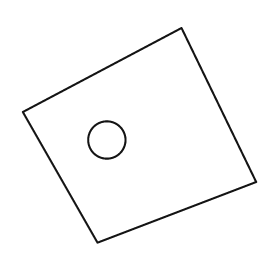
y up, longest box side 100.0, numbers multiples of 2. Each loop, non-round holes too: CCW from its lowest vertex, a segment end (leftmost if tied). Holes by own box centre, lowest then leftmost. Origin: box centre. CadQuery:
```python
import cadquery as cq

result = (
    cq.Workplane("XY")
    .moveTo(-18.0, -46.0)
    .lineTo(50.0, -20.0)
    .lineTo(18.0, 46.0)
    .lineTo(-50.0, 10.0)
    .close()
    .moveTo(-14.0, -2.0)
    .circle(8.0)
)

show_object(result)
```